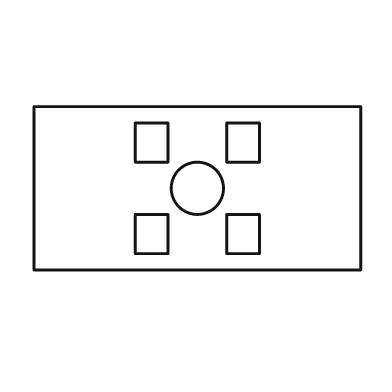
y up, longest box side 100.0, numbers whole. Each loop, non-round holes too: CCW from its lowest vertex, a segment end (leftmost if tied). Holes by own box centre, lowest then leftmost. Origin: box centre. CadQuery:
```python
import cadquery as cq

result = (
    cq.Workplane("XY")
    .moveTo(-50.0, -25.0)
    .lineTo(50.0, -25.0)
    .lineTo(50.0, 25.0)
    .lineTo(-50.0, 25.0)
    .close()
    .moveTo(-19.0, -20.0)
    .lineTo(-9.0, -20.0)
    .lineTo(-9.0, -8.0)
    .lineTo(-19.0, -8.0)
    .close()
    .moveTo(9.0, -20.0)
    .lineTo(19.0, -20.0)
    .lineTo(19.0, -8.0)
    .lineTo(9.0, -8.0)
    .close()
    .moveTo(0.0, 0.0)
    .circle(8.0)
    .moveTo(-19.0, 8.0)
    .lineTo(-9.0, 8.0)
    .lineTo(-9.0, 20.0)
    .lineTo(-19.0, 20.0)
    .close()
    .moveTo(9.0, 8.0)
    .lineTo(19.0, 8.0)
    .lineTo(19.0, 20.0)
    .lineTo(9.0, 20.0)
    .close()
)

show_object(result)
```